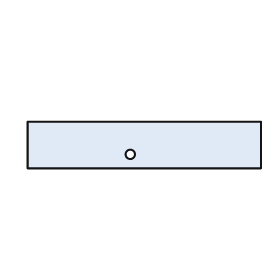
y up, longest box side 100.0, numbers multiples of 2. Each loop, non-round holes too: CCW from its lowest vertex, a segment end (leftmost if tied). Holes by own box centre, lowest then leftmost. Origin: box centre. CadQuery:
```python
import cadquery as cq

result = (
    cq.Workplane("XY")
    .moveTo(-50.0, -10.0)
    .lineTo(50.0, -10.0)
    .lineTo(50.0, 10.0)
    .lineTo(-50.0, 10.0)
    .close()
    .moveTo(-6.0, -4.0)
    .circle(2.0)
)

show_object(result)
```